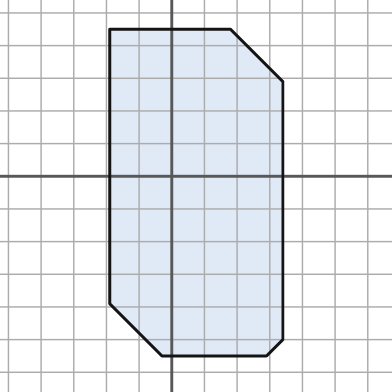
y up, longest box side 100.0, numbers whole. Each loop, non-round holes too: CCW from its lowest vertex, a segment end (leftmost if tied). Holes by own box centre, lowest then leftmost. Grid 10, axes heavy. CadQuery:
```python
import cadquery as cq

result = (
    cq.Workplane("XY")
    .moveTo(-3.0, -55.0)
    .lineTo(29.0, -55.0)
    .lineTo(34.0, -50.0)
    .lineTo(34.0, 29.0)
    .lineTo(18.0, 45.0)
    .lineTo(-19.0, 45.0)
    .lineTo(-19.0, -39.0)
    .close()
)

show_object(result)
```